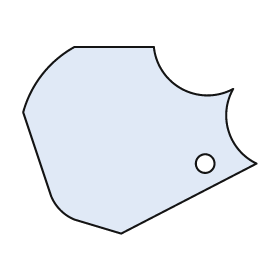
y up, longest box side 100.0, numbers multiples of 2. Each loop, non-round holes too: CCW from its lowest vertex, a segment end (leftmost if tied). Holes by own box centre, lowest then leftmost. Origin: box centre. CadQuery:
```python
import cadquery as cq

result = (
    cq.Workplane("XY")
    .moveTo(-8.0, -40.0)
    .lineTo(50.0, -10.0)
    .threePointArc((38.0, 4.0), (40.0, 22.0))
    .threePointArc((18.0, 22.0), (6.0, 40.0))
    .lineTo(-28.0, 40.0)
    .threePointArc((-42.0, 28.0), (-50.0, 12.0))
    .lineTo(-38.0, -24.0)
    .threePointArc((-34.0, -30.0), (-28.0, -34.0))
    .close()
    .moveTo(28.0, -10.0)
    .circle(4.0)
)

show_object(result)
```